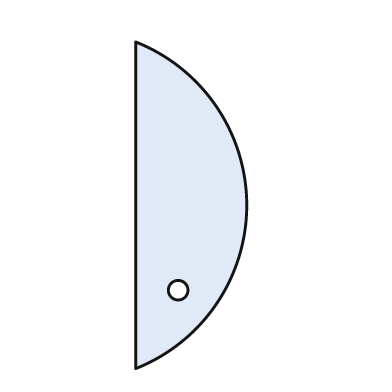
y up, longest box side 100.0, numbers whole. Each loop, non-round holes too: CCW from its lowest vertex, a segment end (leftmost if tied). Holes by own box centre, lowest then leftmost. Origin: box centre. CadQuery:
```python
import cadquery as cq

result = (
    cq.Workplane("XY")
    .moveTo(-17.0, -50.0)
    .threePointArc((17.0, 0.0), (-17.0, 50.0))
    .close()
    .moveTo(-4.0, -26.0)
    .circle(3.0)
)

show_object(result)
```